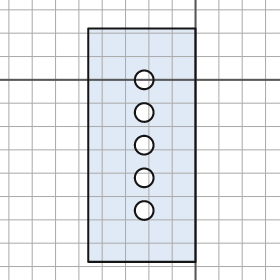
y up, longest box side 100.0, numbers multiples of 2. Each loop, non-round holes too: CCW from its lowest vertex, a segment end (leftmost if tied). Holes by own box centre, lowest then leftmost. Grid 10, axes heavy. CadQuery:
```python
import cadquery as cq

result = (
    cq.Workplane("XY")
    .moveTo(-46.0, -78.0)
    .lineTo(0.0, -78.0)
    .lineTo(0.0, 22.0)
    .lineTo(-46.0, 22.0)
    .close()
    .moveTo(-22.0, -56.0)
    .circle(4.0)
    .moveTo(-22.0, -42.0)
    .circle(4.0)
    .moveTo(-22.0, -28.0)
    .circle(4.0)
    .moveTo(-22.0, -14.0)
    .circle(4.0)
    .moveTo(-22.0, 0.0)
    .circle(4.0)
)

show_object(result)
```